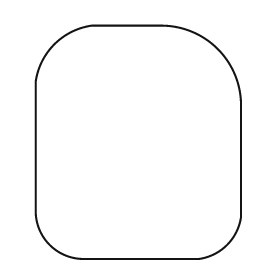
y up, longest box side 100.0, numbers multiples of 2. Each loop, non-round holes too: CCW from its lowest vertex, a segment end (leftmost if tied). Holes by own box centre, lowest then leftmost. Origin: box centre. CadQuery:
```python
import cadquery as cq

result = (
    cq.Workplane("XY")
    .moveTo(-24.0, -50.0)
    .lineTo(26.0, -50.0)
    .threePointArc((38.0, -44.0), (44.0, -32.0))
    .lineTo(44.0, 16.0)
    .threePointArc((34.0, 40.0), (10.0, 50.0))
    .lineTo(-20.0, 50.0)
    .threePointArc((-36.0, 42.0), (-44.0, 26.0))
    .lineTo(-44.0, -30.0)
    .threePointArc((-38.0, -44.0), (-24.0, -50.0))
    .close()
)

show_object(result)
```